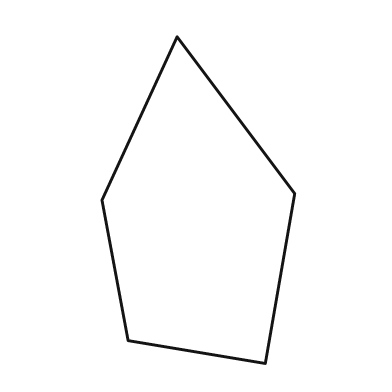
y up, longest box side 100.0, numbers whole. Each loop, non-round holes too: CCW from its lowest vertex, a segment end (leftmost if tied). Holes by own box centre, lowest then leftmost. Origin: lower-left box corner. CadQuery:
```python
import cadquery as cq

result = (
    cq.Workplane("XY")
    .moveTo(50.0, 0.0)
    .lineTo(59.0, 52.0)
    .lineTo(23.0, 100.0)
    .lineTo(0.0, 50.0)
    .lineTo(8.0, 7.0)
    .close()
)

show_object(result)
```